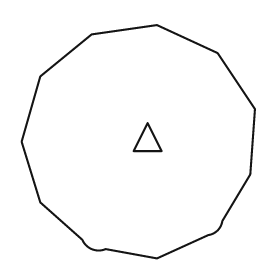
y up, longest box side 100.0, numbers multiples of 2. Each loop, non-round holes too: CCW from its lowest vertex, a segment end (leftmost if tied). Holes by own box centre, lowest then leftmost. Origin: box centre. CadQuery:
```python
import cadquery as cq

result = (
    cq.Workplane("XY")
    .moveTo(8.0, -50.0)
    .lineTo(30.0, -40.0)
    .threePointArc((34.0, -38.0), (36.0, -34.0))
    .lineTo(48.0, -14.0)
    .lineTo(50.0, 14.0)
    .lineTo(34.0, 38.0)
    .lineTo(8.0, 50.0)
    .lineTo(-20.0, 46.0)
    .lineTo(-42.0, 28.0)
    .lineTo(-50.0, 0.0)
    .lineTo(-42.0, -26.0)
    .lineTo(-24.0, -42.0)
    .threePointArc((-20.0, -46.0), (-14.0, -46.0))
    .close()
    .moveTo(-2.0, -4.0)
    .lineTo(10.0, -4.0)
    .lineTo(4.0, 8.0)
    .close()
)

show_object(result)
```